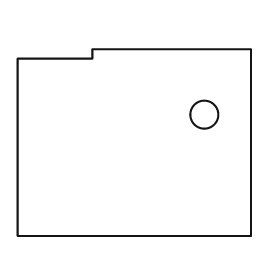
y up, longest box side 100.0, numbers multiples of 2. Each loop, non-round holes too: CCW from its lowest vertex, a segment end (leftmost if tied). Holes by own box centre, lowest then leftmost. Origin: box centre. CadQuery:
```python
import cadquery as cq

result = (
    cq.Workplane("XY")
    .moveTo(-50.0, -40.0)
    .lineTo(50.0, -40.0)
    .lineTo(50.0, 40.0)
    .lineTo(-18.0, 40.0)
    .lineTo(-18.0, 36.0)
    .lineTo(-50.0, 36.0)
    .close()
    .moveTo(30.0, 12.0)
    .circle(6.0)
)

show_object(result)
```